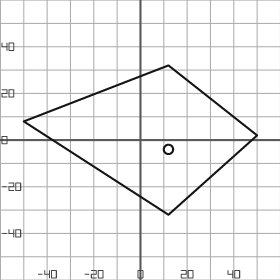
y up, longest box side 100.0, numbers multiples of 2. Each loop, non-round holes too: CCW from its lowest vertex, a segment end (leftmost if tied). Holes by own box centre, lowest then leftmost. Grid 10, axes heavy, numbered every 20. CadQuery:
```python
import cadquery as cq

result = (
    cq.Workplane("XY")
    .moveTo(12.0, -32.0)
    .lineTo(50.0, 2.0)
    .lineTo(12.0, 32.0)
    .lineTo(-50.0, 8.0)
    .close()
    .moveTo(12.0, -4.0)
    .circle(2.0)
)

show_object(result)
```